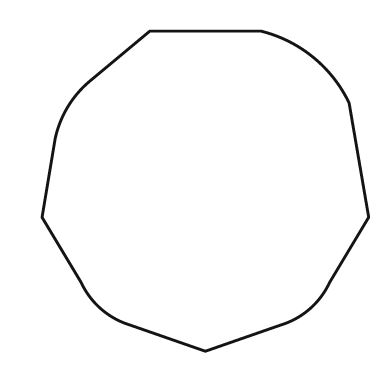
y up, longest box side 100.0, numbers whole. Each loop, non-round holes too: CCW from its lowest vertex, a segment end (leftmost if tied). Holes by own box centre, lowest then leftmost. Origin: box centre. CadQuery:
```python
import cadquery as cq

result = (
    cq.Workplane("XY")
    .moveTo(0.0, -49.0)
    .lineTo(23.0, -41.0)
    .threePointArc((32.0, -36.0), (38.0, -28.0))
    .lineTo(50.0, -8.0)
    .lineTo(44.0, 27.0)
    .threePointArc((33.0, 41.0), (17.0, 49.0))
    .lineTo(-17.0, 49.0)
    .lineTo(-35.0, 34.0)
    .threePointArc((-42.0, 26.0), (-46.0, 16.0))
    .lineTo(-50.0, -8.0)
    .lineTo(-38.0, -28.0)
    .threePointArc((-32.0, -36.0), (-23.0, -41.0))
    .close()
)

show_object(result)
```